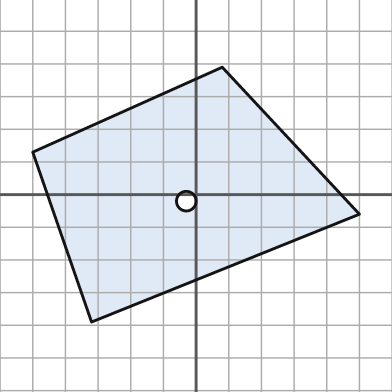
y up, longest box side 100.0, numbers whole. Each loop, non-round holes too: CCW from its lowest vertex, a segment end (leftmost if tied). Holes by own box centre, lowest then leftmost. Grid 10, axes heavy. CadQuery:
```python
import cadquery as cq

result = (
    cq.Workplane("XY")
    .moveTo(-32.0, -39.0)
    .lineTo(50.0, -6.0)
    .lineTo(8.0, 39.0)
    .lineTo(-50.0, 13.0)
    .close()
    .moveTo(-3.0, -2.0)
    .circle(3.0)
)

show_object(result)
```